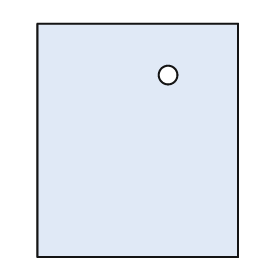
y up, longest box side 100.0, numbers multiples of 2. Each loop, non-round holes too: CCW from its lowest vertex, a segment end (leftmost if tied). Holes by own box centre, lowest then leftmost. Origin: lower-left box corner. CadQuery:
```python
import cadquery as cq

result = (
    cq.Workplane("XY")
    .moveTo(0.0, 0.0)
    .lineTo(86.0, 0.0)
    .lineTo(86.0, 100.0)
    .lineTo(0.0, 100.0)
    .close()
    .moveTo(56.0, 78.0)
    .circle(4.0)
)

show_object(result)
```